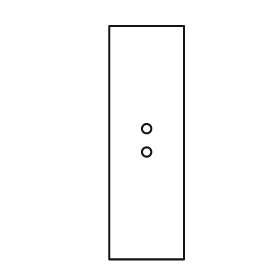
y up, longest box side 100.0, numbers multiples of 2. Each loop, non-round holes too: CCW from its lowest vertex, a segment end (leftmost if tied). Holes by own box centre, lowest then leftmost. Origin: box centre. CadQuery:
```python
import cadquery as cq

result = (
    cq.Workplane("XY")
    .moveTo(-16.0, -50.0)
    .lineTo(16.0, -50.0)
    .lineTo(16.0, 50.0)
    .lineTo(-16.0, 50.0)
    .close()
    .moveTo(0.0, -4.0)
    .circle(2.0)
    .moveTo(0.0, 6.0)
    .circle(2.0)
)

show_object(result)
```